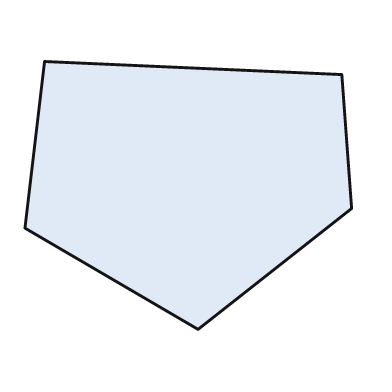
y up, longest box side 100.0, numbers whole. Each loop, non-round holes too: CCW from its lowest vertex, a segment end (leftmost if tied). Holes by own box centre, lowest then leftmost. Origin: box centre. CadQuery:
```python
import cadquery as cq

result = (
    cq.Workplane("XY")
    .moveTo(3.0, -41.0)
    .lineTo(50.0, -4.0)
    .lineTo(47.0, 37.0)
    .lineTo(-44.0, 41.0)
    .lineTo(-50.0, -10.0)
    .close()
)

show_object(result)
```